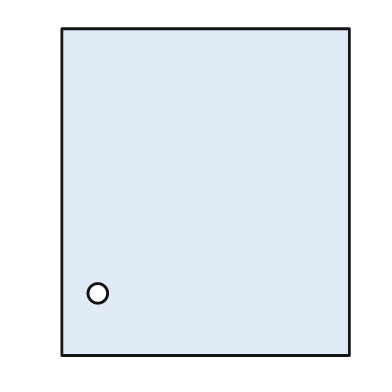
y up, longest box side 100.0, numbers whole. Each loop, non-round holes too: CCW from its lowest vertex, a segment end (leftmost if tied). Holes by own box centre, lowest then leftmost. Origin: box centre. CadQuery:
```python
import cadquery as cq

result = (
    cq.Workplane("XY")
    .moveTo(-44.0, -50.0)
    .lineTo(44.0, -50.0)
    .lineTo(44.0, 50.0)
    .lineTo(-44.0, 50.0)
    .close()
    .moveTo(-33.0, -31.0)
    .circle(3.0)
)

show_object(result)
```